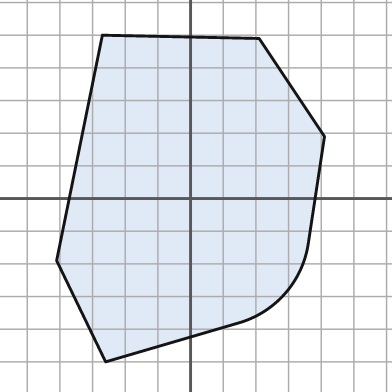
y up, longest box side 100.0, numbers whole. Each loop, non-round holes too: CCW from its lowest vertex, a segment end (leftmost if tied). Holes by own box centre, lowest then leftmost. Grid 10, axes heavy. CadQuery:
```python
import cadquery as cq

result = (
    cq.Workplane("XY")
    .moveTo(-26.0, -50.0)
    .lineTo(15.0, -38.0)
    .threePointArc((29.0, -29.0), (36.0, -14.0))
    .lineTo(41.0, 19.0)
    .lineTo(21.0, 49.0)
    .lineTo(-27.0, 50.0)
    .lineTo(-41.0, -19.0)
    .close()
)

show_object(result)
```